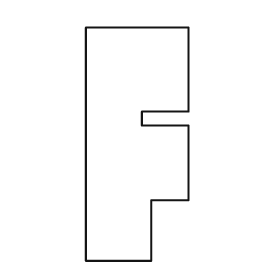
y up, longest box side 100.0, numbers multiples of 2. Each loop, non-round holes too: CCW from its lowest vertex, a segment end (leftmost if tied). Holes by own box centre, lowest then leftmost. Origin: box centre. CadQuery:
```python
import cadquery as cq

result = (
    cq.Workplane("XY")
    .moveTo(-22.0, -50.0)
    .lineTo(6.0, -50.0)
    .lineTo(6.0, -24.0)
    .lineTo(22.0, -24.0)
    .lineTo(22.0, 8.0)
    .lineTo(2.0, 8.0)
    .lineTo(2.0, 14.0)
    .lineTo(22.0, 14.0)
    .lineTo(22.0, 50.0)
    .lineTo(-22.0, 50.0)
    .close()
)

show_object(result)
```